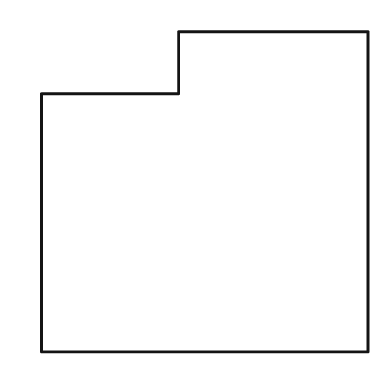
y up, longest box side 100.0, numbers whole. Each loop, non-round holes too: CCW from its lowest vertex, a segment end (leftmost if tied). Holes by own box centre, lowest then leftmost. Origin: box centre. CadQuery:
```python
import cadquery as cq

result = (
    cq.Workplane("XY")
    .moveTo(-50.0, -49.0)
    .lineTo(50.0, -49.0)
    .lineTo(50.0, 49.0)
    .lineTo(-8.0, 49.0)
    .lineTo(-8.0, 30.0)
    .lineTo(-50.0, 30.0)
    .close()
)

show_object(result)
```